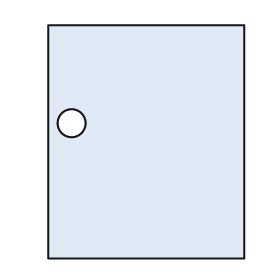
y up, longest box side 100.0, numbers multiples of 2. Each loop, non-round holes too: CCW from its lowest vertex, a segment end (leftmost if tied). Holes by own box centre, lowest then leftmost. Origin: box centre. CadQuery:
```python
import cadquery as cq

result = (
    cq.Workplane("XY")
    .moveTo(-42.0, -50.0)
    .lineTo(42.0, -50.0)
    .lineTo(42.0, 50.0)
    .lineTo(-42.0, 50.0)
    .close()
    .moveTo(-32.0, 8.0)
    .circle(6.0)
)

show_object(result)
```